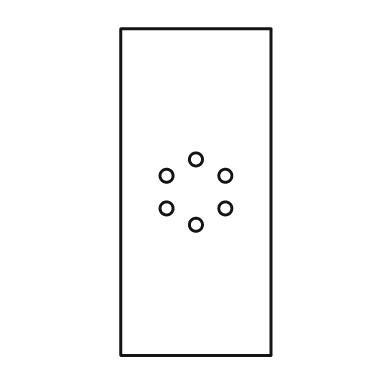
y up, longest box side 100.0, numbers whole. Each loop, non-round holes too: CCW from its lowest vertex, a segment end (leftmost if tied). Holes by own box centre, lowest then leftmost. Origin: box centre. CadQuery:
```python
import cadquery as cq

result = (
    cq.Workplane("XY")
    .moveTo(-23.0, -50.0)
    .lineTo(23.0, -50.0)
    .lineTo(23.0, 50.0)
    .lineTo(-23.0, 50.0)
    .close()
    .moveTo(0.0, -10.0)
    .circle(2.0)
    .moveTo(-9.0, -5.0)
    .circle(2.0)
    .moveTo(9.0, -5.0)
    .circle(2.0)
    .moveTo(-9.0, 5.0)
    .circle(2.0)
    .moveTo(9.0, 5.0)
    .circle(2.0)
    .moveTo(0.0, 10.0)
    .circle(2.0)
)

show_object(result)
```